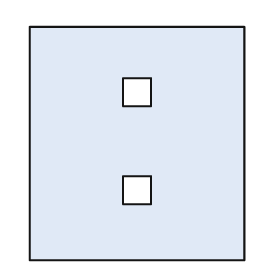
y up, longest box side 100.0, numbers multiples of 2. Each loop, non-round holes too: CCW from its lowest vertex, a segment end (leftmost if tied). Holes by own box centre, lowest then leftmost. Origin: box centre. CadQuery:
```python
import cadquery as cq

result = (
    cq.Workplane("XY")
    .moveTo(-46.0, -50.0)
    .lineTo(46.0, -50.0)
    .lineTo(46.0, 50.0)
    .lineTo(-46.0, 50.0)
    .close()
    .moveTo(-6.0, -26.0)
    .lineTo(6.0, -26.0)
    .lineTo(6.0, -14.0)
    .lineTo(-6.0, -14.0)
    .close()
    .moveTo(-6.0, 16.0)
    .lineTo(6.0, 16.0)
    .lineTo(6.0, 28.0)
    .lineTo(-6.0, 28.0)
    .close()
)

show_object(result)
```